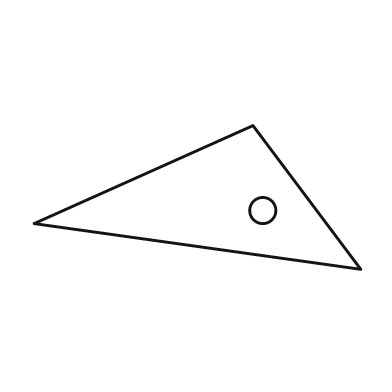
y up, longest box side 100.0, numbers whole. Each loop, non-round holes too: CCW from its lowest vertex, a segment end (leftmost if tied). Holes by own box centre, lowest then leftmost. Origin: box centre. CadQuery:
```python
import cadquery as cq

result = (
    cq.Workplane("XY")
    .moveTo(50.0, -22.0)
    .lineTo(17.0, 22.0)
    .lineTo(-50.0, -8.0)
    .close()
    .moveTo(20.0, -4.0)
    .circle(4.0)
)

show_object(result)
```